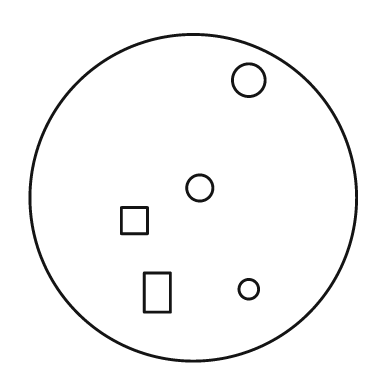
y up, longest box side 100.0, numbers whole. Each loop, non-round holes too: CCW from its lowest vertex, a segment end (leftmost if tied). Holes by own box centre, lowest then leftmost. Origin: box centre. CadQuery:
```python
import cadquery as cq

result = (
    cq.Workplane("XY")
    .moveTo(0.0, 0.0)
    .circle(50.0)
    .moveTo(-15.0, -35.0)
    .lineTo(-7.0, -35.0)
    .lineTo(-7.0, -23.0)
    .lineTo(-15.0, -23.0)
    .close()
    .moveTo(17.0, -28.0)
    .circle(3.0)
    .moveTo(-22.0, -11.0)
    .lineTo(-14.0, -11.0)
    .lineTo(-14.0, -3.0)
    .lineTo(-22.0, -3.0)
    .close()
    .moveTo(2.0, 3.0)
    .circle(4.0)
    .moveTo(17.0, 36.0)
    .circle(5.0)
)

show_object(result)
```